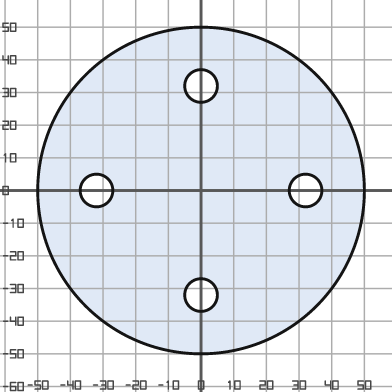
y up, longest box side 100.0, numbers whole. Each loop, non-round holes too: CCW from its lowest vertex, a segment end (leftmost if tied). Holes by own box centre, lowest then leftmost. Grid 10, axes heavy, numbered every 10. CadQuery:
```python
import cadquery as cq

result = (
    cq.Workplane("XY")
    .moveTo(0.0, 0.0)
    .circle(50.0)
    .moveTo(0.0, -32.0)
    .circle(5.0)
    .moveTo(-32.0, 0.0)
    .circle(5.0)
    .moveTo(32.0, 0.0)
    .circle(5.0)
    .moveTo(0.0, 32.0)
    .circle(5.0)
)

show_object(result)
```